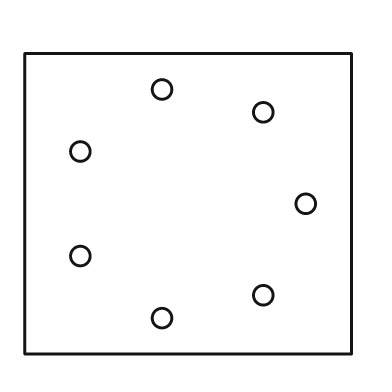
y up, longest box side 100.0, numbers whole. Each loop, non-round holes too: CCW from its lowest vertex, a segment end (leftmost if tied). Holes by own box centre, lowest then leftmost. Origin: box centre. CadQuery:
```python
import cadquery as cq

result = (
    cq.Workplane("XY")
    .moveTo(-50.0, -46.0)
    .lineTo(50.0, -46.0)
    .lineTo(50.0, 46.0)
    .lineTo(-50.0, 46.0)
    .close()
    .moveTo(-8.0, -35.0)
    .circle(3.0)
    .moveTo(23.0, -28.0)
    .circle(3.0)
    .moveTo(-33.0, -16.0)
    .circle(3.0)
    .moveTo(36.0, 0.0)
    .circle(3.0)
    .moveTo(-33.0, 16.0)
    .circle(3.0)
    .moveTo(23.0, 28.0)
    .circle(3.0)
    .moveTo(-8.0, 35.0)
    .circle(3.0)
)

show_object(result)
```